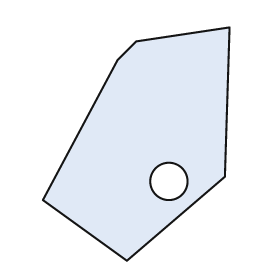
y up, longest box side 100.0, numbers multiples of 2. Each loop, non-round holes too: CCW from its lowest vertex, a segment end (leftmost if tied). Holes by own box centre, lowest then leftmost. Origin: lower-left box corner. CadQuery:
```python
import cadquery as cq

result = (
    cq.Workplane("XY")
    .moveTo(36.0, 0.0)
    .lineTo(78.0, 36.0)
    .lineTo(80.0, 100.0)
    .lineTo(40.0, 94.0)
    .lineTo(32.0, 86.0)
    .lineTo(0.0, 26.0)
    .close()
    .moveTo(54.0, 34.0)
    .circle(8.0)
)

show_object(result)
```